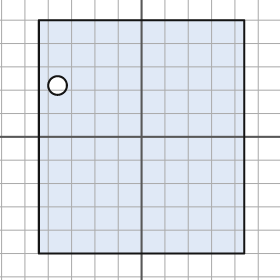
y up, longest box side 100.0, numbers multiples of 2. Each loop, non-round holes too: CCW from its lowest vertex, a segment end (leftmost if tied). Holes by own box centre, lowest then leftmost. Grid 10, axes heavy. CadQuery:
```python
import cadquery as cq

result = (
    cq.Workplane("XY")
    .moveTo(-44.0, -50.0)
    .lineTo(44.0, -50.0)
    .lineTo(44.0, 50.0)
    .lineTo(-44.0, 50.0)
    .close()
    .moveTo(-36.0, 22.0)
    .circle(4.0)
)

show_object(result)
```